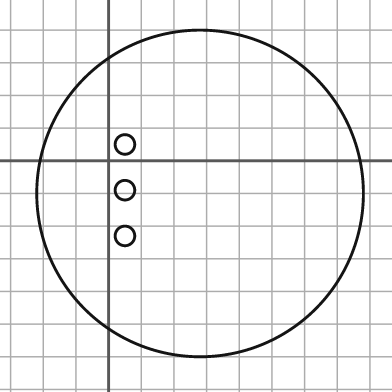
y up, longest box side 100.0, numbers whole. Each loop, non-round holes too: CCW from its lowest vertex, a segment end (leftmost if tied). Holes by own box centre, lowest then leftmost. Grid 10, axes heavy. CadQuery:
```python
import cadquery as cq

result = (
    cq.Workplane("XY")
    .moveTo(28.0, -10.0)
    .circle(50.0)
    .moveTo(5.0, -23.0)
    .circle(3.0)
    .moveTo(5.0, -9.0)
    .circle(3.0)
    .moveTo(5.0, 5.0)
    .circle(3.0)
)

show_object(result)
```